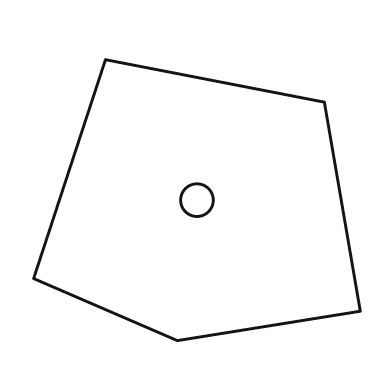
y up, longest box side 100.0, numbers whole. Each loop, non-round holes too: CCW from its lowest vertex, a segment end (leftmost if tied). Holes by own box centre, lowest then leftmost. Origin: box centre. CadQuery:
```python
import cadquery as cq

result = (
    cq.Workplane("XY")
    .moveTo(-6.0, -43.0)
    .lineTo(50.0, -34.0)
    .lineTo(39.0, 30.0)
    .lineTo(-28.0, 43.0)
    .lineTo(-50.0, -24.0)
    .close()
    .moveTo(0.0, 0.0)
    .circle(5.0)
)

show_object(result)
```